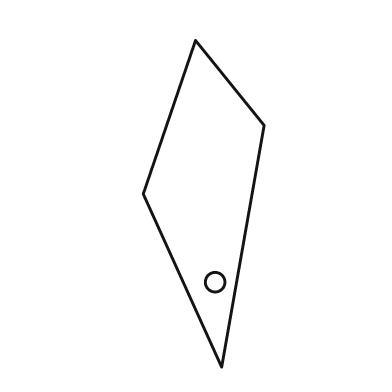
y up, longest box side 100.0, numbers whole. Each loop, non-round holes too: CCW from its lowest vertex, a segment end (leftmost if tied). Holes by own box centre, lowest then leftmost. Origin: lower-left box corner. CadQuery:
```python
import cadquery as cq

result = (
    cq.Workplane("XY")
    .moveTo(24.0, 0.0)
    .lineTo(37.0, 74.0)
    .lineTo(16.0, 100.0)
    .lineTo(0.0, 53.0)
    .close()
    .moveTo(22.0, 26.0)
    .circle(3.0)
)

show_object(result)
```